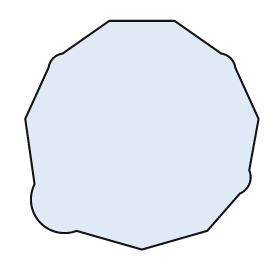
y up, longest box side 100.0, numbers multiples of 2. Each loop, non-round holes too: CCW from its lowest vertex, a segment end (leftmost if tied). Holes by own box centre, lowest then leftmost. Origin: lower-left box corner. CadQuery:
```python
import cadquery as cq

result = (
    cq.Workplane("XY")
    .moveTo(50.0, 0.0)
    .lineTo(78.0, 8.0)
    .lineTo(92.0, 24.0)
    .threePointArc((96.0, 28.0), (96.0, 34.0))
    .lineTo(100.0, 56.0)
    .lineTo(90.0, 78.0)
    .threePointArc((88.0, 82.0), (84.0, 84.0))
    .lineTo(64.0, 98.0)
    .lineTo(36.0, 98.0)
    .lineTo(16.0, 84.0)
    .threePointArc((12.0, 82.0), (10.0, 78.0))
    .lineTo(0.0, 56.0)
    .lineTo(4.0, 28.0)
    .threePointArc((6.0, 12.0), (22.0, 8.0))
    .close()
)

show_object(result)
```